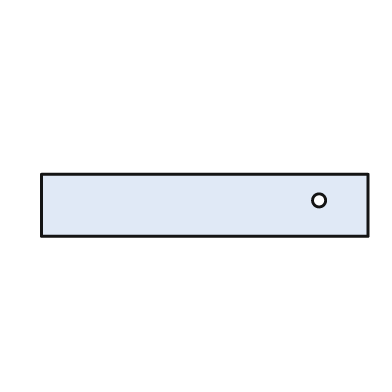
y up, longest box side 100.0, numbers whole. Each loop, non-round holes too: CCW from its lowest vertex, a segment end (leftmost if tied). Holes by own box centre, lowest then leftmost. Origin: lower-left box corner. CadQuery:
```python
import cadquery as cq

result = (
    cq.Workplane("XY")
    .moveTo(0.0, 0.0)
    .lineTo(100.0, 0.0)
    .lineTo(100.0, 19.0)
    .lineTo(0.0, 19.0)
    .close()
    .moveTo(85.0, 11.0)
    .circle(2.0)
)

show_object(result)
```